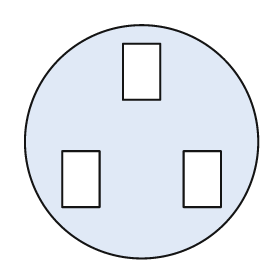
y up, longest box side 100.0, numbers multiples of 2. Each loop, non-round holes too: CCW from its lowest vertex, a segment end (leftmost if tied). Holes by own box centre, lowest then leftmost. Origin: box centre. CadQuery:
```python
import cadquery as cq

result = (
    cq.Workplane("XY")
    .moveTo(0.0, 0.0)
    .circle(50.0)
    .moveTo(-34.0, -28.0)
    .lineTo(-18.0, -28.0)
    .lineTo(-18.0, -4.0)
    .lineTo(-34.0, -4.0)
    .close()
    .moveTo(18.0, -28.0)
    .lineTo(34.0, -28.0)
    .lineTo(34.0, -4.0)
    .lineTo(18.0, -4.0)
    .close()
    .moveTo(-8.0, 18.0)
    .lineTo(8.0, 18.0)
    .lineTo(8.0, 42.0)
    .lineTo(-8.0, 42.0)
    .close()
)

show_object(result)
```